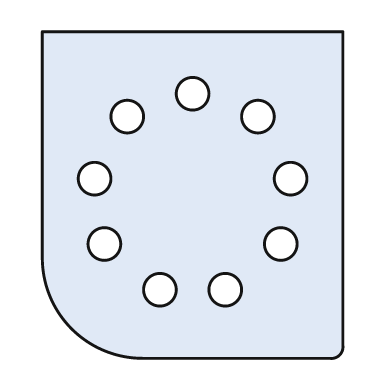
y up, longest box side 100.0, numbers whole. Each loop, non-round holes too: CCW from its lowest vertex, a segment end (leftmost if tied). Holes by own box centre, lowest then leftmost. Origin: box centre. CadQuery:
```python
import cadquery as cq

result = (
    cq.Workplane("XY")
    .moveTo(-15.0, -50.0)
    .lineTo(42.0, -50.0)
    .threePointArc((45.0, -49.0), (46.0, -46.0))
    .lineTo(46.0, 50.0)
    .lineTo(-46.0, 50.0)
    .lineTo(-46.0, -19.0)
    .threePointArc((-37.0, -41.0), (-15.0, -50.0))
    .close()
    .moveTo(-10.0, -29.0)
    .circle(5.0)
    .moveTo(10.0, -29.0)
    .circle(5.0)
    .moveTo(-27.0, -15.0)
    .circle(5.0)
    .moveTo(27.0, -15.0)
    .circle(5.0)
    .moveTo(-30.0, 5.0)
    .circle(5.0)
    .moveTo(30.0, 5.0)
    .circle(5.0)
    .moveTo(-20.0, 24.0)
    .circle(5.0)
    .moveTo(20.0, 24.0)
    .circle(5.0)
    .moveTo(0.0, 31.0)
    .circle(5.0)
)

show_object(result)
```